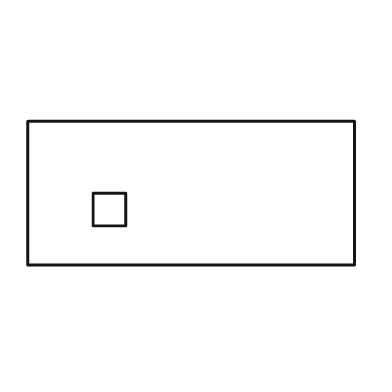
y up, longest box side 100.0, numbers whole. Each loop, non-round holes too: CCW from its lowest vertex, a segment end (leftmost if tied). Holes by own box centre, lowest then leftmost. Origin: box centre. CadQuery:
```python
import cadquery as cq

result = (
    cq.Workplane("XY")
    .moveTo(-50.0, -22.0)
    .lineTo(50.0, -22.0)
    .lineTo(50.0, 22.0)
    .lineTo(-50.0, 22.0)
    .close()
    .moveTo(-30.0, -10.0)
    .lineTo(-20.0, -10.0)
    .lineTo(-20.0, 0.0)
    .lineTo(-30.0, 0.0)
    .close()
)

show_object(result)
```